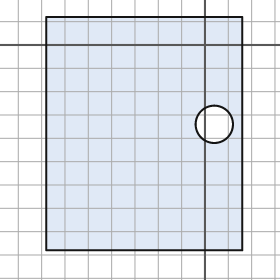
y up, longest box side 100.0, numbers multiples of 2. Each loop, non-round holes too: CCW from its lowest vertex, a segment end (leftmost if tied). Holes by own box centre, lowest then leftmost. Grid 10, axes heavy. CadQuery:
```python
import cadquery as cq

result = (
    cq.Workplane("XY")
    .moveTo(-68.0, -88.0)
    .lineTo(16.0, -88.0)
    .lineTo(16.0, 12.0)
    .lineTo(-68.0, 12.0)
    .close()
    .moveTo(4.0, -34.0)
    .circle(8.0)
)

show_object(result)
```